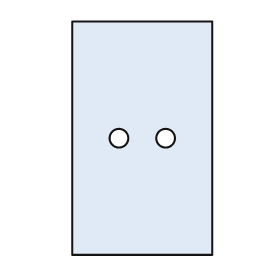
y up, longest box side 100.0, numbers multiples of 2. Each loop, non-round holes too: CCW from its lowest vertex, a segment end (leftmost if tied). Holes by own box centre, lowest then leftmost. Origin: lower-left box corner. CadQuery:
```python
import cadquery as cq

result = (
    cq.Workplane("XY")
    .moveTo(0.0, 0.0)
    .lineTo(60.0, 0.0)
    .lineTo(60.0, 100.0)
    .lineTo(0.0, 100.0)
    .close()
    .moveTo(20.0, 50.0)
    .circle(4.0)
    .moveTo(40.0, 50.0)
    .circle(4.0)
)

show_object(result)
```